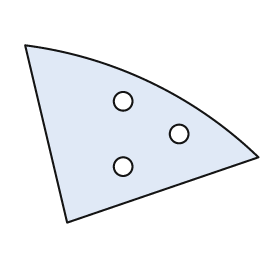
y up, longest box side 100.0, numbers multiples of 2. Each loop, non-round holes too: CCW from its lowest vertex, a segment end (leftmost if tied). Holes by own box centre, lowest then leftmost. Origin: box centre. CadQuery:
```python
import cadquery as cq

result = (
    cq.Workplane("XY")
    .moveTo(-32.0, -38.0)
    .lineTo(50.0, -10.0)
    .threePointArc((4.0, 22.0), (-50.0, 38.0))
    .close()
    .moveTo(-8.0, -14.0)
    .circle(4.0)
    .moveTo(16.0, 0.0)
    .circle(4.0)
    .moveTo(-8.0, 14.0)
    .circle(4.0)
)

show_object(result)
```